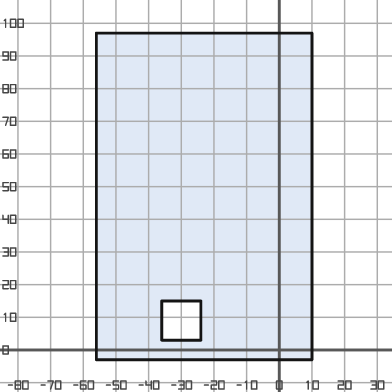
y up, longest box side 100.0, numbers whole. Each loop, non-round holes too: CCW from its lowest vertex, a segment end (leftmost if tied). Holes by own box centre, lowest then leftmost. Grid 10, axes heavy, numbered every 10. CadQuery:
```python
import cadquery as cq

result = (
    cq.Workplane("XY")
    .moveTo(-56.0, -3.0)
    .lineTo(10.0, -3.0)
    .lineTo(10.0, 97.0)
    .lineTo(-56.0, 97.0)
    .close()
    .moveTo(-36.0, 3.0)
    .lineTo(-24.0, 3.0)
    .lineTo(-24.0, 15.0)
    .lineTo(-36.0, 15.0)
    .close()
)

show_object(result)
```